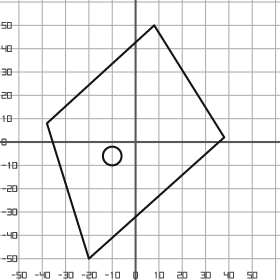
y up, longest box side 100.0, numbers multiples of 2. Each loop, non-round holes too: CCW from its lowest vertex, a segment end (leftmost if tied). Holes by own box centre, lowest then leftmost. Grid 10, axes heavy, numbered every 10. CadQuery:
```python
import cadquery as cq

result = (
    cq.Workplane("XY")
    .moveTo(-20.0, -50.0)
    .lineTo(38.0, 2.0)
    .lineTo(8.0, 50.0)
    .lineTo(-38.0, 8.0)
    .close()
    .moveTo(-10.0, -6.0)
    .circle(4.0)
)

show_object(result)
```